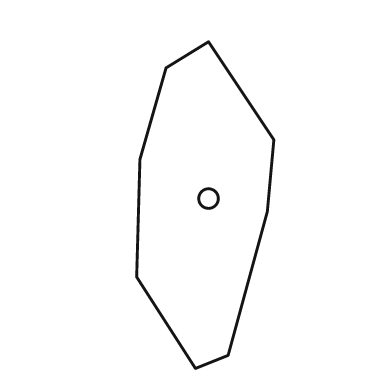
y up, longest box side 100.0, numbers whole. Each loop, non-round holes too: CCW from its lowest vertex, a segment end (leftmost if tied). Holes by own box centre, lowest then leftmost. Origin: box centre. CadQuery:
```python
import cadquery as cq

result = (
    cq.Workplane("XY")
    .moveTo(-3.0, -50.0)
    .lineTo(7.0, -46.0)
    .lineTo(19.0, -2.0)
    .lineTo(21.0, 20.0)
    .lineTo(1.0, 50.0)
    .lineTo(-12.0, 42.0)
    .lineTo(-20.0, 14.0)
    .lineTo(-21.0, -22.0)
    .close()
    .moveTo(1.0, 2.0)
    .circle(3.0)
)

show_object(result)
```